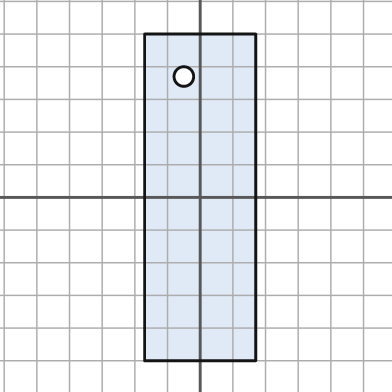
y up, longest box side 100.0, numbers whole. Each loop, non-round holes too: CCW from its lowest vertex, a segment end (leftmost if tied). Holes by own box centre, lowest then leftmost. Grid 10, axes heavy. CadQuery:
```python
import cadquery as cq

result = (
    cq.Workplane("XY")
    .moveTo(-17.0, -50.0)
    .lineTo(17.0, -50.0)
    .lineTo(17.0, 50.0)
    .lineTo(-17.0, 50.0)
    .close()
    .moveTo(-5.0, 37.0)
    .circle(3.0)
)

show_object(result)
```